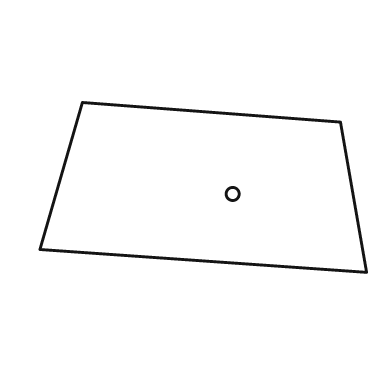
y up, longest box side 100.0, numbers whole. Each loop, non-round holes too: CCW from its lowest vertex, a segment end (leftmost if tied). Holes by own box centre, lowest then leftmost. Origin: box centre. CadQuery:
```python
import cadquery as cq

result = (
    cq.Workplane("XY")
    .moveTo(50.0, -26.0)
    .lineTo(42.0, 20.0)
    .lineTo(-37.0, 26.0)
    .lineTo(-50.0, -19.0)
    .close()
    .moveTo(9.0, -2.0)
    .circle(2.0)
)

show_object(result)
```